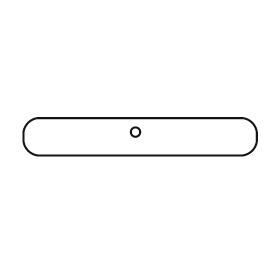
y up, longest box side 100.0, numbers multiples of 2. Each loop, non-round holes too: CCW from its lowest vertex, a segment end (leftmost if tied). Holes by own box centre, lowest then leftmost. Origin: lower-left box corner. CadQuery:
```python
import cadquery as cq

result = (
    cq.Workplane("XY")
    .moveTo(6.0, 0.0)
    .lineTo(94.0, 0.0)
    .threePointArc((98.0, 2.0), (100.0, 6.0))
    .lineTo(100.0, 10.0)
    .threePointArc((98.0, 14.0), (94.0, 16.0))
    .lineTo(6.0, 16.0)
    .threePointArc((2.0, 14.0), (0.0, 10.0))
    .lineTo(0.0, 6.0)
    .threePointArc((2.0, 2.0), (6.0, 0.0))
    .close()
    .moveTo(48.0, 10.0)
    .circle(2.0)
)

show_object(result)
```